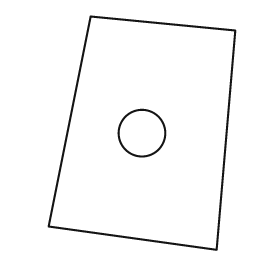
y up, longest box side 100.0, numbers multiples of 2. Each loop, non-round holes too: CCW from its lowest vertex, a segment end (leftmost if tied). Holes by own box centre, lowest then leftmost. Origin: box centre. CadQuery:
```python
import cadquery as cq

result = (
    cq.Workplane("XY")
    .moveTo(32.0, -50.0)
    .lineTo(40.0, 44.0)
    .lineTo(-22.0, 50.0)
    .lineTo(-40.0, -40.0)
    .close()
    .moveTo(0.0, 0.0)
    .circle(10.0)
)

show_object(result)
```